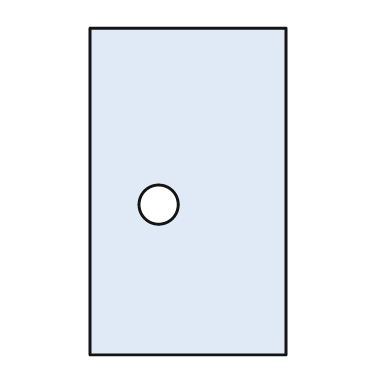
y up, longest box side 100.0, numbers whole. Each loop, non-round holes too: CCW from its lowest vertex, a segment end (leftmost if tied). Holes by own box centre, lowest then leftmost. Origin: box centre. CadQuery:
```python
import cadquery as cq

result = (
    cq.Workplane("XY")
    .moveTo(-30.0, -50.0)
    .lineTo(30.0, -50.0)
    .lineTo(30.0, 50.0)
    .lineTo(-30.0, 50.0)
    .close()
    .moveTo(-9.0, -4.0)
    .circle(6.0)
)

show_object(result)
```